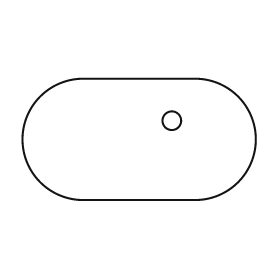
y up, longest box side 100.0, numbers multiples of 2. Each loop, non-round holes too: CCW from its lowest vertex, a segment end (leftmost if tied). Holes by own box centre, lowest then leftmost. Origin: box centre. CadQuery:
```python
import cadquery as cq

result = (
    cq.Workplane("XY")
    .moveTo(-24.0, -26.0)
    .lineTo(24.0, -26.0)
    .threePointArc((50.0, 0.0), (24.0, 26.0))
    .lineTo(-24.0, 26.0)
    .threePointArc((-50.0, 0.0), (-24.0, -26.0))
    .close()
    .moveTo(14.0, 8.0)
    .circle(4.0)
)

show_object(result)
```